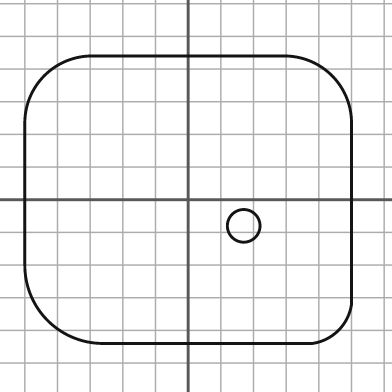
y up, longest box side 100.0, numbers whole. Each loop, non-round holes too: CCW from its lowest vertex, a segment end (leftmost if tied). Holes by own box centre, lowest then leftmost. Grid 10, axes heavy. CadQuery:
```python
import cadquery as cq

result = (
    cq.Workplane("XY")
    .moveTo(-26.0, -44.0)
    .lineTo(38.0, -44.0)
    .threePointArc((46.0, -40.0), (50.0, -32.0))
    .lineTo(50.0, 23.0)
    .threePointArc((44.0, 38.0), (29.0, 44.0))
    .lineTo(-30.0, 44.0)
    .threePointArc((-44.0, 38.0), (-50.0, 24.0))
    .lineTo(-50.0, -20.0)
    .threePointArc((-43.0, -37.0), (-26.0, -44.0))
    .close()
    .moveTo(17.0, -8.0)
    .circle(5.0)
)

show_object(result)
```